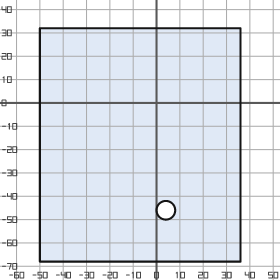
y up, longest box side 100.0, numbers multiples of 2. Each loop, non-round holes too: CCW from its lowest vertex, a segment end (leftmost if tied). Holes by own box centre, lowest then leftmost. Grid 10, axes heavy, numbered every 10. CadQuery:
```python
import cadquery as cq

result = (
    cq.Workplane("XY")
    .moveTo(-50.0, -68.0)
    .lineTo(36.0, -68.0)
    .lineTo(36.0, 32.0)
    .lineTo(-50.0, 32.0)
    .close()
    .moveTo(4.0, -46.0)
    .circle(4.0)
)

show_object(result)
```